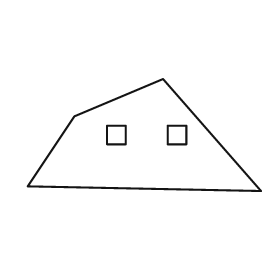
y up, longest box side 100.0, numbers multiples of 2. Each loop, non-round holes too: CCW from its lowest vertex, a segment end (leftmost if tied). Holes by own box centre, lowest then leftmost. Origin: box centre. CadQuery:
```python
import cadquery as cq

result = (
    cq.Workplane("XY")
    .moveTo(50.0, -24.0)
    .lineTo(8.0, 24.0)
    .lineTo(-30.0, 8.0)
    .lineTo(-50.0, -22.0)
    .close()
    .moveTo(-16.0, -4.0)
    .lineTo(-8.0, -4.0)
    .lineTo(-8.0, 4.0)
    .lineTo(-16.0, 4.0)
    .close()
    .moveTo(10.0, -4.0)
    .lineTo(18.0, -4.0)
    .lineTo(18.0, 4.0)
    .lineTo(10.0, 4.0)
    .close()
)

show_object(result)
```